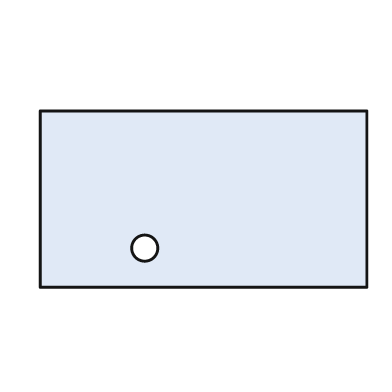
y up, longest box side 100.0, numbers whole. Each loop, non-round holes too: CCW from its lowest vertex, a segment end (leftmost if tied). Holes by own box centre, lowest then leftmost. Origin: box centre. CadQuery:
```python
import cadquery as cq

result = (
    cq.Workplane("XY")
    .moveTo(-50.0, -27.0)
    .lineTo(50.0, -27.0)
    .lineTo(50.0, 27.0)
    .lineTo(-50.0, 27.0)
    .close()
    .moveTo(-18.0, -15.0)
    .circle(4.0)
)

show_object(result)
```